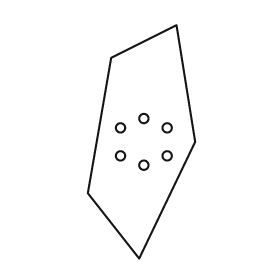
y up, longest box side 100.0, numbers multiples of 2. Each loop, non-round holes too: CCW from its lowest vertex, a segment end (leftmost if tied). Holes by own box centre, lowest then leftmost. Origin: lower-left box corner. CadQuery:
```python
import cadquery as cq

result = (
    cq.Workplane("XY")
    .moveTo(22.0, 0.0)
    .lineTo(46.0, 50.0)
    .lineTo(38.0, 100.0)
    .lineTo(10.0, 86.0)
    .lineTo(0.0, 28.0)
    .close()
    .moveTo(24.0, 40.0)
    .circle(2.0)
    .moveTo(14.0, 44.0)
    .circle(2.0)
    .moveTo(34.0, 44.0)
    .circle(2.0)
    .moveTo(14.0, 56.0)
    .circle(2.0)
    .moveTo(34.0, 56.0)
    .circle(2.0)
    .moveTo(24.0, 60.0)
    .circle(2.0)
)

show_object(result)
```